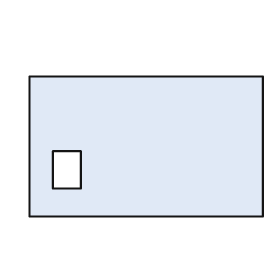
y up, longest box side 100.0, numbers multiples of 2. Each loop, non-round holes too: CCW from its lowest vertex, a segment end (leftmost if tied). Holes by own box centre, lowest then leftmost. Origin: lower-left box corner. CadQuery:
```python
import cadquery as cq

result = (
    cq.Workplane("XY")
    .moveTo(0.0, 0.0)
    .lineTo(100.0, 0.0)
    .lineTo(100.0, 60.0)
    .lineTo(0.0, 60.0)
    .close()
    .moveTo(10.0, 12.0)
    .lineTo(22.0, 12.0)
    .lineTo(22.0, 28.0)
    .lineTo(10.0, 28.0)
    .close()
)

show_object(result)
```